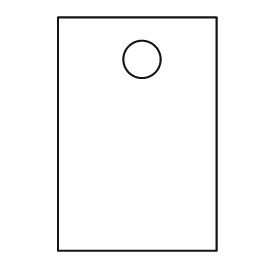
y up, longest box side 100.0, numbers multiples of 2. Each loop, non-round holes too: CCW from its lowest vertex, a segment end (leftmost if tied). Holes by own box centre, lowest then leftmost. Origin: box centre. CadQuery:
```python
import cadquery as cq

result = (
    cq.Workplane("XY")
    .moveTo(-34.0, -50.0)
    .lineTo(34.0, -50.0)
    .lineTo(34.0, 50.0)
    .lineTo(-34.0, 50.0)
    .close()
    .moveTo(2.0, 32.0)
    .circle(8.0)
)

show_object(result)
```